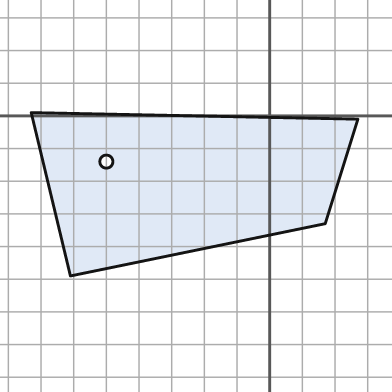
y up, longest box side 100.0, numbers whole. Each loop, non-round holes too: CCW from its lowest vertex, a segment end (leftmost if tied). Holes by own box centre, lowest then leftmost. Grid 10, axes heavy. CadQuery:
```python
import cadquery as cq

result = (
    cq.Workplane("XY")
    .moveTo(-61.0, -49.0)
    .lineTo(17.0, -33.0)
    .lineTo(27.0, -1.0)
    .lineTo(-73.0, 1.0)
    .close()
    .moveTo(-50.0, -14.0)
    .circle(2.0)
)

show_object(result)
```